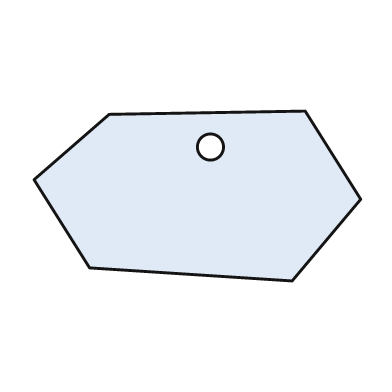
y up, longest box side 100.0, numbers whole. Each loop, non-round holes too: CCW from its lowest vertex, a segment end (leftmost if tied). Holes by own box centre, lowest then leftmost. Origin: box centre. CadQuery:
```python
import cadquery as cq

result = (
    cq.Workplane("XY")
    .moveTo(29.0, -26.0)
    .lineTo(50.0, -1.0)
    .lineTo(33.0, 26.0)
    .lineTo(-27.0, 25.0)
    .lineTo(-50.0, 5.0)
    .lineTo(-33.0, -22.0)
    .close()
    .moveTo(4.0, 15.0)
    .circle(4.0)
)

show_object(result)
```